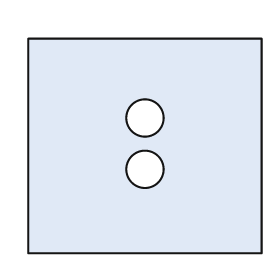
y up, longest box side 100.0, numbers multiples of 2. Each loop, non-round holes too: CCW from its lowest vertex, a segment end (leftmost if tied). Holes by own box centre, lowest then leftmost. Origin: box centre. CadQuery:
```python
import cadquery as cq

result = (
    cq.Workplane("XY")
    .moveTo(-50.0, -46.0)
    .lineTo(50.0, -46.0)
    .lineTo(50.0, 46.0)
    .lineTo(-50.0, 46.0)
    .close()
    .moveTo(0.0, -10.0)
    .circle(8.0)
    .moveTo(0.0, 12.0)
    .circle(8.0)
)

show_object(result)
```